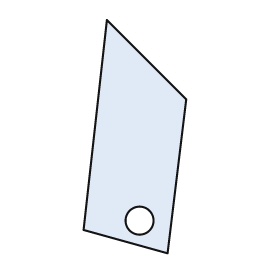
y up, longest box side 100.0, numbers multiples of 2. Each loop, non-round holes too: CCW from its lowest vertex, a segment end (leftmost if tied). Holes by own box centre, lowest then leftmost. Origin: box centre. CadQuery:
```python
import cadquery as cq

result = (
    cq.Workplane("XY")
    .moveTo(14.0, -50.0)
    .lineTo(22.0, 16.0)
    .lineTo(-12.0, 50.0)
    .lineTo(-22.0, -40.0)
    .close()
    .moveTo(2.0, -36.0)
    .circle(6.0)
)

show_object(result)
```